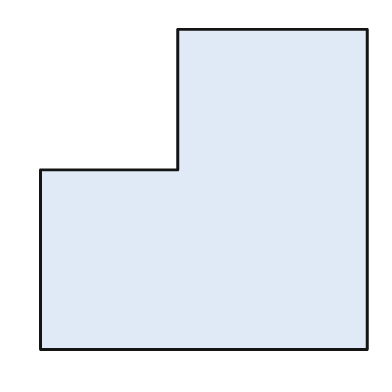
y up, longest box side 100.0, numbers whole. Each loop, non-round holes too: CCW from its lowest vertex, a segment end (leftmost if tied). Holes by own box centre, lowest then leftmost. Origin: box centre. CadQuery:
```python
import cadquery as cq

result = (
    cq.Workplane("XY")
    .moveTo(-50.0, -49.0)
    .lineTo(50.0, -49.0)
    .lineTo(50.0, 49.0)
    .lineTo(-8.0, 49.0)
    .lineTo(-8.0, 6.0)
    .lineTo(-50.0, 6.0)
    .close()
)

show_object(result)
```